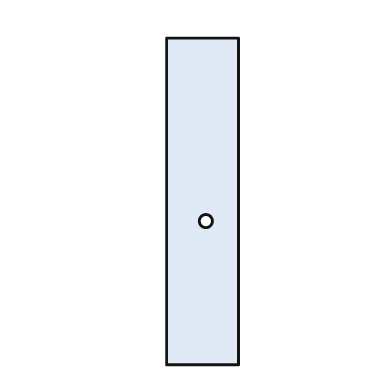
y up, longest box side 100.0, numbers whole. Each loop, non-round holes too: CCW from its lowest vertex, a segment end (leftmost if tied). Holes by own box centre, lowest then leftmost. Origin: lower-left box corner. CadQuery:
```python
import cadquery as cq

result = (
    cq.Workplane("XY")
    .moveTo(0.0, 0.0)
    .lineTo(22.0, 0.0)
    .lineTo(22.0, 100.0)
    .lineTo(0.0, 100.0)
    .close()
    .moveTo(12.0, 44.0)
    .circle(2.0)
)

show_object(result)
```